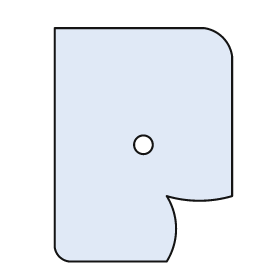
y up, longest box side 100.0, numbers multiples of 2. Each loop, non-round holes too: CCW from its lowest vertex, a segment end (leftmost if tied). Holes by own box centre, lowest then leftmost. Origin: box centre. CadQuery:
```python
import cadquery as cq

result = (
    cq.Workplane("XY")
    .moveTo(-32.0, -50.0)
    .lineTo(10.0, -50.0)
    .threePointArc((14.0, -36.0), (10.0, -22.0))
    .threePointArc((24.0, -24.0), (38.0, -22.0))
    .lineTo(38.0, 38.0)
    .threePointArc((34.0, 46.0), (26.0, 50.0))
    .lineTo(-38.0, 50.0)
    .lineTo(-38.0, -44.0)
    .threePointArc((-36.0, -48.0), (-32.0, -50.0))
    .close()
    .moveTo(0.0, 0.0)
    .circle(4.0)
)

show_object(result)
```